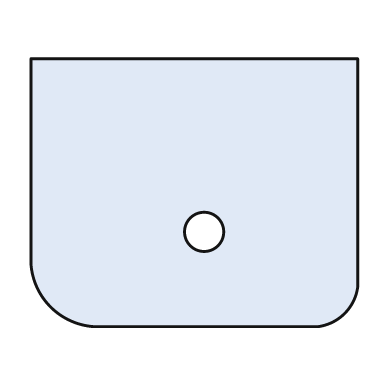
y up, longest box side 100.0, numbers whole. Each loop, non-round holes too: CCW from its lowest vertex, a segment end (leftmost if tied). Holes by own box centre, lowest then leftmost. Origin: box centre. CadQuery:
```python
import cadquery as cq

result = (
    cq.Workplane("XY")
    .moveTo(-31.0, -41.0)
    .lineTo(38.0, -41.0)
    .threePointArc((46.0, -37.0), (50.0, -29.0))
    .lineTo(50.0, 41.0)
    .lineTo(-50.0, 41.0)
    .lineTo(-50.0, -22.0)
    .threePointArc((-44.0, -35.0), (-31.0, -41.0))
    .close()
    .moveTo(3.0, -12.0)
    .circle(6.0)
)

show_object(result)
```